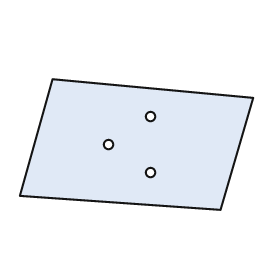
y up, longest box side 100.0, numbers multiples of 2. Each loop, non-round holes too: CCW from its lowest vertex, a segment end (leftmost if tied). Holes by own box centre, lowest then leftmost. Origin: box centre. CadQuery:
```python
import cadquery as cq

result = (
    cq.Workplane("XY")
    .moveTo(36.0, -28.0)
    .lineTo(50.0, 20.0)
    .lineTo(-36.0, 28.0)
    .lineTo(-50.0, -22.0)
    .close()
    .moveTo(6.0, -12.0)
    .circle(2.0)
    .moveTo(-12.0, 0.0)
    .circle(2.0)
    .moveTo(6.0, 12.0)
    .circle(2.0)
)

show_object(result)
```